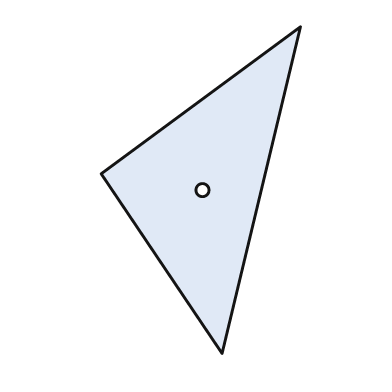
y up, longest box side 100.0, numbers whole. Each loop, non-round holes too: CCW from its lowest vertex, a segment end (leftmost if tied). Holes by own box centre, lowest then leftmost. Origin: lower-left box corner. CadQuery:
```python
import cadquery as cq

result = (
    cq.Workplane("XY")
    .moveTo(37.0, 0.0)
    .lineTo(61.0, 100.0)
    .lineTo(0.0, 55.0)
    .close()
    .moveTo(31.0, 50.0)
    .circle(2.0)
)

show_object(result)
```